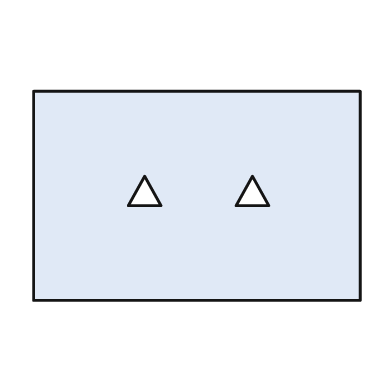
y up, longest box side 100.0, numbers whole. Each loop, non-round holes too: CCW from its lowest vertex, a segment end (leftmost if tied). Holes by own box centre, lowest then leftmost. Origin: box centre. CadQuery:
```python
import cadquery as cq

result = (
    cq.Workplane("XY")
    .moveTo(-50.0, -32.0)
    .lineTo(50.0, -32.0)
    .lineTo(50.0, 32.0)
    .lineTo(-50.0, 32.0)
    .close()
    .moveTo(-21.0, -3.0)
    .lineTo(-11.0, -3.0)
    .lineTo(-16.0, 6.0)
    .close()
    .moveTo(12.0, -3.0)
    .lineTo(22.0, -3.0)
    .lineTo(17.0, 6.0)
    .close()
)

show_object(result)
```